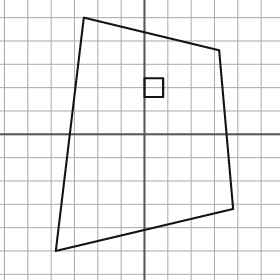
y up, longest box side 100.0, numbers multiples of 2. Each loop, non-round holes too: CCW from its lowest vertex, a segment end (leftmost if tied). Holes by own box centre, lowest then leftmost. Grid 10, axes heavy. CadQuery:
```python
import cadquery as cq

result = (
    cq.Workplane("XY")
    .moveTo(-38.0, -50.0)
    .lineTo(38.0, -32.0)
    .lineTo(32.0, 36.0)
    .lineTo(-26.0, 50.0)
    .close()
    .moveTo(0.0, 16.0)
    .lineTo(8.0, 16.0)
    .lineTo(8.0, 24.0)
    .lineTo(0.0, 24.0)
    .close()
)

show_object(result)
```